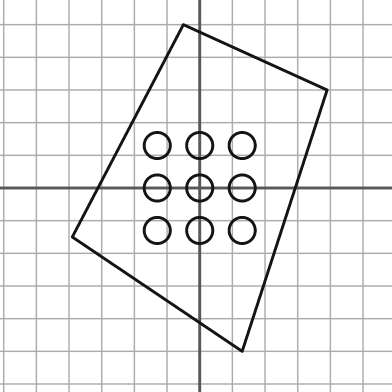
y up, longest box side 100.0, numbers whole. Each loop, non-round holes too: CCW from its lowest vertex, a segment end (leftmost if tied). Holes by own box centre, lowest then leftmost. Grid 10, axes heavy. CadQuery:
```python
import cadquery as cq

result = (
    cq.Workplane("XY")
    .moveTo(13.0, -50.0)
    .lineTo(39.0, 30.0)
    .lineTo(-5.0, 50.0)
    .lineTo(-39.0, -15.0)
    .close()
    .moveTo(-13.0, -13.0)
    .circle(4.0)
    .moveTo(0.0, -13.0)
    .circle(4.0)
    .moveTo(13.0, -13.0)
    .circle(4.0)
    .moveTo(-13.0, 0.0)
    .circle(4.0)
    .moveTo(0.0, 0.0)
    .circle(4.0)
    .moveTo(13.0, 0.0)
    .circle(4.0)
    .moveTo(-13.0, 13.0)
    .circle(4.0)
    .moveTo(0.0, 13.0)
    .circle(4.0)
    .moveTo(13.0, 13.0)
    .circle(4.0)
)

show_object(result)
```